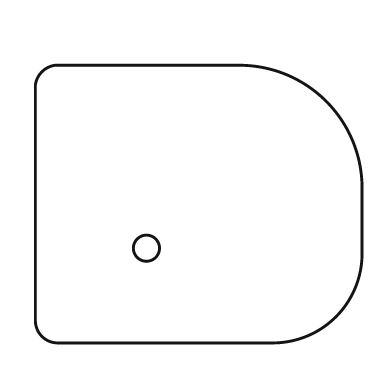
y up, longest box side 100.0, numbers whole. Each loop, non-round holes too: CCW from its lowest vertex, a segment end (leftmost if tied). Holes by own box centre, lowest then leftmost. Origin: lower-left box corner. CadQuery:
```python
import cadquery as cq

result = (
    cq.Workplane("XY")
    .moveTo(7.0, 0.0)
    .lineTo(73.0, 0.0)
    .threePointArc((92.0, 8.0), (100.0, 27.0))
    .lineTo(100.0, 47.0)
    .threePointArc((89.0, 74.0), (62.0, 85.0))
    .lineTo(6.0, 85.0)
    .threePointArc((2.0, 83.0), (0.0, 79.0))
    .lineTo(0.0, 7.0)
    .threePointArc((2.0, 2.0), (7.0, 0.0))
    .close()
    .moveTo(34.0, 29.0)
    .circle(4.0)
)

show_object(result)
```